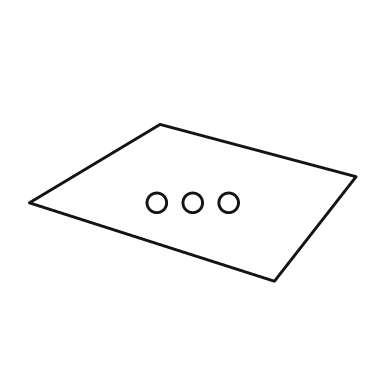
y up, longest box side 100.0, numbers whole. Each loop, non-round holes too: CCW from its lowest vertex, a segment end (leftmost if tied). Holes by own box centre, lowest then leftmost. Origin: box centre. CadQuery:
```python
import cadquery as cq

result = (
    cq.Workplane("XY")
    .moveTo(25.0, -24.0)
    .lineTo(50.0, 8.0)
    .lineTo(-10.0, 24.0)
    .lineTo(-50.0, 0.0)
    .close()
    .moveTo(-11.0, 0.0)
    .circle(3.0)
    .moveTo(0.0, 0.0)
    .circle(3.0)
    .moveTo(11.0, 0.0)
    .circle(3.0)
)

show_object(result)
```